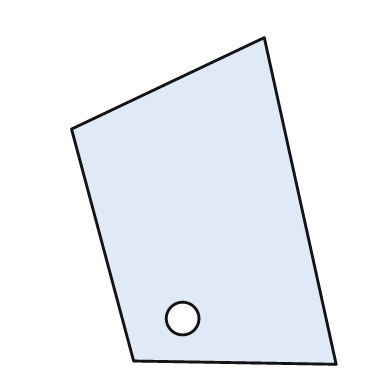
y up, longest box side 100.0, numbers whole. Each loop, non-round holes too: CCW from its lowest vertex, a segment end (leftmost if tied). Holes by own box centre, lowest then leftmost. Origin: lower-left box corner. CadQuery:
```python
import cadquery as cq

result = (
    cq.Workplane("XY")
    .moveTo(81.0, 0.0)
    .lineTo(59.0, 100.0)
    .lineTo(0.0, 72.0)
    .lineTo(19.0, 1.0)
    .close()
    .moveTo(34.0, 14.0)
    .circle(5.0)
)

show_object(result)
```